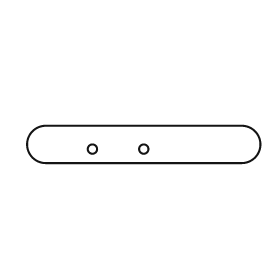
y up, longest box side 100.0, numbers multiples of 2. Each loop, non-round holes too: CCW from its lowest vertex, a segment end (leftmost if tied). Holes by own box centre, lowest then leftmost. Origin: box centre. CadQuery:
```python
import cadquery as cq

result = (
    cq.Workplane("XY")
    .moveTo(-42.0, -8.0)
    .lineTo(42.0, -8.0)
    .threePointArc((50.0, 0.0), (42.0, 8.0))
    .lineTo(-42.0, 8.0)
    .threePointArc((-50.0, 0.0), (-42.0, -8.0))
    .close()
    .moveTo(-22.0, -2.0)
    .circle(2.0)
    .moveTo(0.0, -2.0)
    .circle(2.0)
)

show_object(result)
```